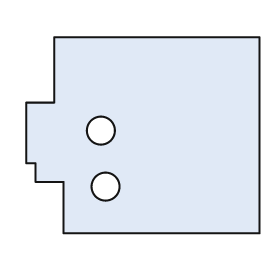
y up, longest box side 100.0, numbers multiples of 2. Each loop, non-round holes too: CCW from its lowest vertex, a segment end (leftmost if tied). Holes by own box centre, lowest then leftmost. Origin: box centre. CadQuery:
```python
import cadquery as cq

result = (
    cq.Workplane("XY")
    .moveTo(-34.0, -42.0)
    .lineTo(50.0, -42.0)
    .lineTo(50.0, 42.0)
    .lineTo(-38.0, 42.0)
    .lineTo(-38.0, 14.0)
    .lineTo(-50.0, 14.0)
    .lineTo(-50.0, -12.0)
    .lineTo(-46.0, -12.0)
    .lineTo(-46.0, -20.0)
    .lineTo(-34.0, -20.0)
    .close()
    .moveTo(-16.0, -22.0)
    .circle(6.0)
    .moveTo(-18.0, 2.0)
    .circle(6.0)
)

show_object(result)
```